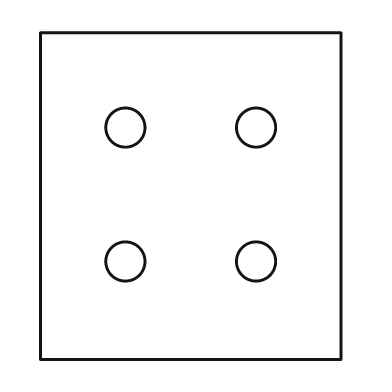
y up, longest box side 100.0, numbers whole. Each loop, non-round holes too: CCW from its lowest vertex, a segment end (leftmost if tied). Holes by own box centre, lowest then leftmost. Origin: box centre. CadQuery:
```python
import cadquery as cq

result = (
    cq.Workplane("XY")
    .moveTo(-46.0, -50.0)
    .lineTo(46.0, -50.0)
    .lineTo(46.0, 50.0)
    .lineTo(-46.0, 50.0)
    .close()
    .moveTo(-20.0, -20.0)
    .circle(6.0)
    .moveTo(20.0, -20.0)
    .circle(6.0)
    .moveTo(-20.0, 21.0)
    .circle(6.0)
    .moveTo(20.0, 21.0)
    .circle(6.0)
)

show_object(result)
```